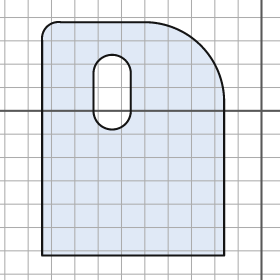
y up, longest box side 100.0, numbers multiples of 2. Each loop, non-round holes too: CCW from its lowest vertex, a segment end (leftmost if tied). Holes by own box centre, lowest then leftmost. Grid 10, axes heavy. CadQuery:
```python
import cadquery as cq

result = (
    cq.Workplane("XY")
    .moveTo(-94.0, -62.0)
    .lineTo(-16.0, -62.0)
    .lineTo(-16.0, 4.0)
    .threePointArc((-26.0, 28.0), (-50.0, 38.0))
    .lineTo(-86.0, 38.0)
    .threePointArc((-92.0, 36.0), (-94.0, 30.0))
    .close()
    .moveTo(-72.0, 0.0)
    .threePointArc((-64.0, -8.0), (-56.0, 0.0))
    .lineTo(-56.0, 16.0)
    .threePointArc((-64.0, 24.0), (-72.0, 16.0))
    .close()
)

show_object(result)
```